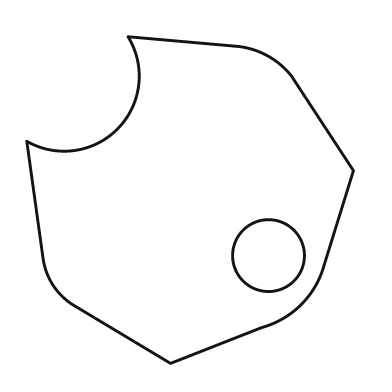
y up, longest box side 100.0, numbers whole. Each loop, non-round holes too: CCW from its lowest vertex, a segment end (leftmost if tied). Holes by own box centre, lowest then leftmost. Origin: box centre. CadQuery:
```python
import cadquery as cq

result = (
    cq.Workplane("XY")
    .moveTo(-6.0, -50.0)
    .lineTo(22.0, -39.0)
    .threePointArc((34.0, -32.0), (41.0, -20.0))
    .lineTo(50.0, 9.0)
    .lineTo(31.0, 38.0)
    .threePointArc((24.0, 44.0), (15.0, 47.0))
    .lineTo(-19.0, 50.0)
    .threePointArc((-22.0, 22.0), (-50.0, 18.0))
    .lineTo(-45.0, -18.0)
    .threePointArc((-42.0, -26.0), (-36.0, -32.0))
    .close()
    .moveTo(24.0, -17.0)
    .circle(11.0)
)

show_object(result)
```